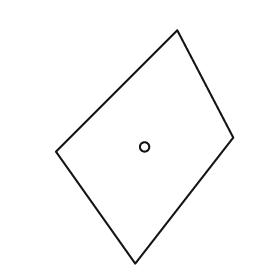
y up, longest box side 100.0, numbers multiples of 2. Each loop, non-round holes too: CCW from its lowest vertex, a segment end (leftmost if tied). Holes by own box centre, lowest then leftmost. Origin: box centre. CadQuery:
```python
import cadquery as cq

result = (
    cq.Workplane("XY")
    .moveTo(-4.0, -50.0)
    .lineTo(38.0, 4.0)
    .lineTo(14.0, 50.0)
    .lineTo(-38.0, -2.0)
    .close()
    .moveTo(0.0, 0.0)
    .circle(2.0)
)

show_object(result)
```